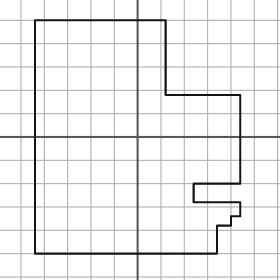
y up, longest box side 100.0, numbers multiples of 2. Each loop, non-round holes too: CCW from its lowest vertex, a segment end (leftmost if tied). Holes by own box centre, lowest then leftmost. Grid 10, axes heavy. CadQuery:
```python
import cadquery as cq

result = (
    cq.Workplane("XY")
    .moveTo(-44.0, -50.0)
    .lineTo(34.0, -50.0)
    .lineTo(34.0, -38.0)
    .lineTo(40.0, -38.0)
    .lineTo(40.0, -34.0)
    .lineTo(44.0, -34.0)
    .lineTo(44.0, -28.0)
    .lineTo(24.0, -28.0)
    .lineTo(24.0, -20.0)
    .lineTo(44.0, -20.0)
    .lineTo(44.0, 18.0)
    .lineTo(12.0, 18.0)
    .lineTo(12.0, 50.0)
    .lineTo(-44.0, 50.0)
    .close()
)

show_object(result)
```